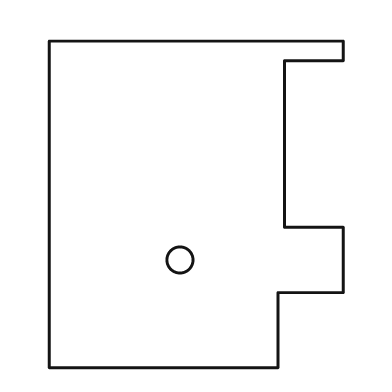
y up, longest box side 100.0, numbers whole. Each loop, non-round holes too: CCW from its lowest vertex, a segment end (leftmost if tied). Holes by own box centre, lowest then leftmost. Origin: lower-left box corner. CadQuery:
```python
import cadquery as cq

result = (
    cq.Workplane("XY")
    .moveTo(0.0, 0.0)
    .lineTo(70.0, 0.0)
    .lineTo(70.0, 23.0)
    .lineTo(90.0, 23.0)
    .lineTo(90.0, 43.0)
    .lineTo(72.0, 43.0)
    .lineTo(72.0, 94.0)
    .lineTo(90.0, 94.0)
    .lineTo(90.0, 100.0)
    .lineTo(0.0, 100.0)
    .close()
    .moveTo(40.0, 33.0)
    .circle(4.0)
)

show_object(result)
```